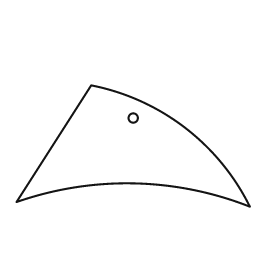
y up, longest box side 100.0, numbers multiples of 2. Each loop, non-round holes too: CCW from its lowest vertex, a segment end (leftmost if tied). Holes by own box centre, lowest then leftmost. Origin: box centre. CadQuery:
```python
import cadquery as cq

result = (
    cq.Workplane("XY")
    .moveTo(50.0, -26.0)
    .threePointArc((22.0, 8.0), (-18.0, 26.0))
    .lineTo(-50.0, -24.0)
    .threePointArc((0.0, -16.0), (50.0, -26.0))
    .close()
    .moveTo(0.0, 12.0)
    .circle(2.0)
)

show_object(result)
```